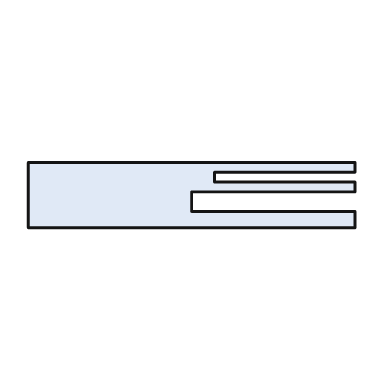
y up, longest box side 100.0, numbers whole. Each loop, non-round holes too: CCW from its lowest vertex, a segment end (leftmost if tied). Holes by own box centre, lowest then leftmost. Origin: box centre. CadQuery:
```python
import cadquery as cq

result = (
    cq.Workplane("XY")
    .moveTo(-50.0, -10.0)
    .lineTo(50.0, -10.0)
    .lineTo(50.0, -5.0)
    .lineTo(0.0, -5.0)
    .lineTo(0.0, 1.0)
    .lineTo(50.0, 1.0)
    .lineTo(50.0, 4.0)
    .lineTo(7.0, 4.0)
    .lineTo(7.0, 7.0)
    .lineTo(50.0, 7.0)
    .lineTo(50.0, 10.0)
    .lineTo(-50.0, 10.0)
    .close()
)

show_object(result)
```